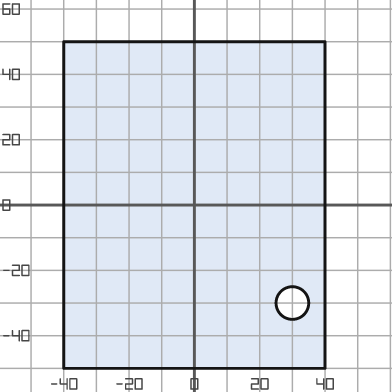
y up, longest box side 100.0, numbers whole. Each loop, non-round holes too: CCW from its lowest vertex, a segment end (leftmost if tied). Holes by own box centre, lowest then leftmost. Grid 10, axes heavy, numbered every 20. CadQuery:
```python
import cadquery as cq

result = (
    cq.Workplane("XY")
    .moveTo(-40.0, -50.0)
    .lineTo(40.0, -50.0)
    .lineTo(40.0, 50.0)
    .lineTo(-40.0, 50.0)
    .close()
    .moveTo(30.0, -30.0)
    .circle(5.0)
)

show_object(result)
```